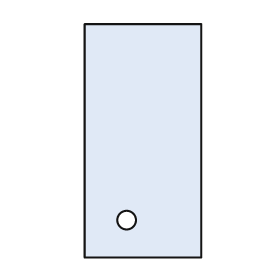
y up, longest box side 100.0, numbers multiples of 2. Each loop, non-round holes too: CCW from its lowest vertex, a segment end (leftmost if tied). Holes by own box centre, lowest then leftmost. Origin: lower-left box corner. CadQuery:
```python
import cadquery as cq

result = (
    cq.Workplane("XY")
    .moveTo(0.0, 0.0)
    .lineTo(50.0, 0.0)
    .lineTo(50.0, 100.0)
    .lineTo(0.0, 100.0)
    .close()
    .moveTo(18.0, 16.0)
    .circle(4.0)
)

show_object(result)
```